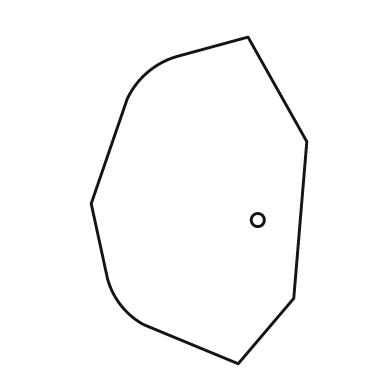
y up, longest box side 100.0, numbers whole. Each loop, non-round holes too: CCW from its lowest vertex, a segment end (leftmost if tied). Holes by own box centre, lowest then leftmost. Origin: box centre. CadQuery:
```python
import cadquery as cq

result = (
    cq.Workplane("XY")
    .moveTo(12.0, -50.0)
    .lineTo(29.0, -30.0)
    .lineTo(33.0, 18.0)
    .lineTo(15.0, 50.0)
    .lineTo(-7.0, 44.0)
    .threePointArc((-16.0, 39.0), (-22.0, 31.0))
    .lineTo(-33.0, -1.0)
    .lineTo(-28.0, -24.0)
    .threePointArc((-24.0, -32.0), (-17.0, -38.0))
    .close()
    .moveTo(18.0, -6.0)
    .circle(2.0)
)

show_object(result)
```